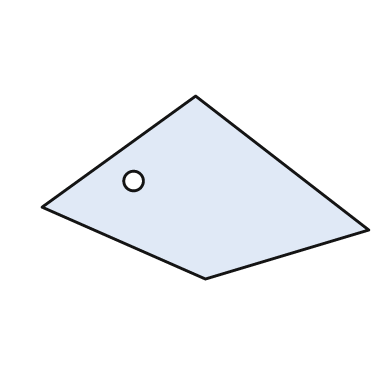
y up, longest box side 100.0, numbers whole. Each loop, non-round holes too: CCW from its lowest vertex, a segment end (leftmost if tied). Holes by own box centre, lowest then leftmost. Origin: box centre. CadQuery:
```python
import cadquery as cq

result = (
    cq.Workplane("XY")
    .moveTo(0.0, -28.0)
    .lineTo(50.0, -13.0)
    .lineTo(-3.0, 28.0)
    .lineTo(-50.0, -6.0)
    .close()
    .moveTo(-22.0, 2.0)
    .circle(3.0)
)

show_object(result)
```